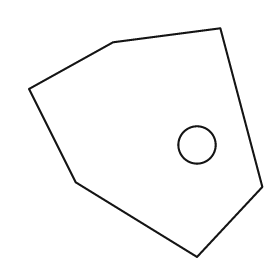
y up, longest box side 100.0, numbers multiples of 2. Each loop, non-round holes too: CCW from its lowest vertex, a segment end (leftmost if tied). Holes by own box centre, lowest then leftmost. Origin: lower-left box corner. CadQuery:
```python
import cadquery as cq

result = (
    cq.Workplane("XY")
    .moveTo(72.0, 0.0)
    .lineTo(100.0, 30.0)
    .lineTo(82.0, 98.0)
    .lineTo(36.0, 92.0)
    .lineTo(0.0, 72.0)
    .lineTo(20.0, 32.0)
    .close()
    .moveTo(72.0, 48.0)
    .circle(8.0)
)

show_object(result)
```